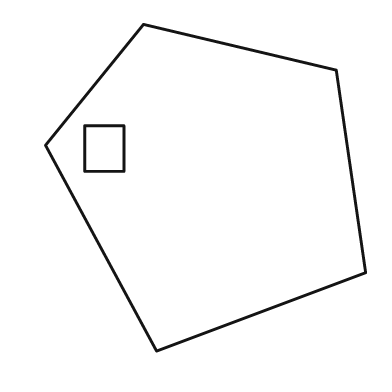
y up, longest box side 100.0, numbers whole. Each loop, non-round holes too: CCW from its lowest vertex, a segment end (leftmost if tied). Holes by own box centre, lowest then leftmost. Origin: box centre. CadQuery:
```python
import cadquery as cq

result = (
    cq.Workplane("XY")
    .moveTo(-15.0, -50.0)
    .lineTo(49.0, -26.0)
    .lineTo(40.0, 36.0)
    .lineTo(-19.0, 50.0)
    .lineTo(-49.0, 13.0)
    .close()
    .moveTo(-37.0, 5.0)
    .lineTo(-25.0, 5.0)
    .lineTo(-25.0, 19.0)
    .lineTo(-37.0, 19.0)
    .close()
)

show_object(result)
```